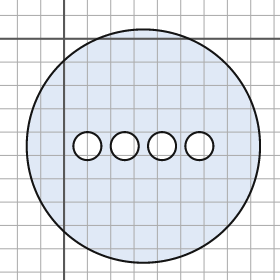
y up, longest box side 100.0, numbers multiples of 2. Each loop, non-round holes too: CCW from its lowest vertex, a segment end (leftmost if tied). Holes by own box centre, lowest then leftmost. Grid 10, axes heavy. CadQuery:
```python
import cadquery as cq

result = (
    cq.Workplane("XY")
    .moveTo(34.0, -46.0)
    .circle(50.0)
    .moveTo(10.0, -46.0)
    .circle(6.0)
    .moveTo(26.0, -46.0)
    .circle(6.0)
    .moveTo(42.0, -46.0)
    .circle(6.0)
    .moveTo(58.0, -46.0)
    .circle(6.0)
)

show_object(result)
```